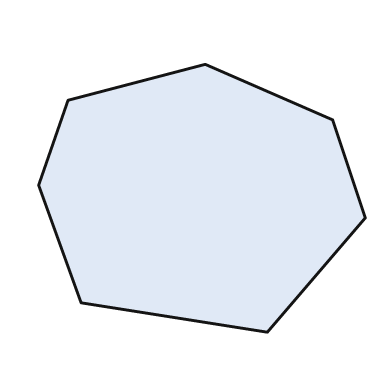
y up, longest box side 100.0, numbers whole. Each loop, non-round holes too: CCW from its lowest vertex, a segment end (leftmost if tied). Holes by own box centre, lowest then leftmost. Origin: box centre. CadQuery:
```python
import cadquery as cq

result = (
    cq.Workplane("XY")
    .moveTo(20.0, -41.0)
    .lineTo(50.0, -6.0)
    .lineTo(40.0, 24.0)
    .lineTo(1.0, 41.0)
    .lineTo(-41.0, 30.0)
    .lineTo(-50.0, 4.0)
    .lineTo(-37.0, -32.0)
    .close()
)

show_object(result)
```